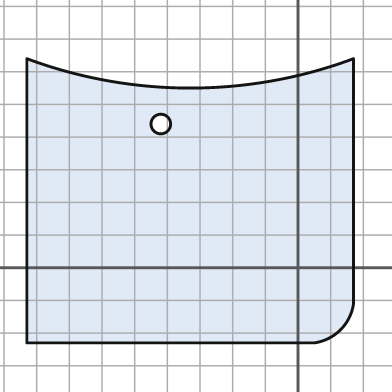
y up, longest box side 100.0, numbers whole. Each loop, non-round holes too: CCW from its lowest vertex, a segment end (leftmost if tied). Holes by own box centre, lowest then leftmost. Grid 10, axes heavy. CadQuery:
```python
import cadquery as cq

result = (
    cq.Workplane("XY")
    .moveTo(-83.0, -23.0)
    .lineTo(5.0, -23.0)
    .threePointArc((13.0, -19.0), (17.0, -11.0))
    .lineTo(17.0, 64.0)
    .threePointArc((-33.0, 55.0), (-83.0, 64.0))
    .close()
    .moveTo(-42.0, 44.0)
    .circle(3.0)
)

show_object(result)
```